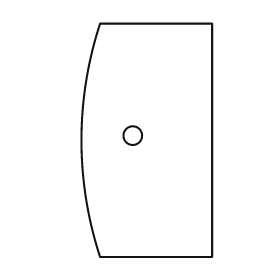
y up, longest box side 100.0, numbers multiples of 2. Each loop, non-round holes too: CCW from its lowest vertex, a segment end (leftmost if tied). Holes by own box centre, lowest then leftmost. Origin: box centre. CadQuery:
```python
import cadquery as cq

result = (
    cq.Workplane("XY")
    .moveTo(-20.0, -50.0)
    .lineTo(28.0, -50.0)
    .lineTo(28.0, 50.0)
    .lineTo(-20.0, 50.0)
    .threePointArc((-28.0, 0.0), (-20.0, -50.0))
    .close()
    .moveTo(-6.0, 2.0)
    .circle(4.0)
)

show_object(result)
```